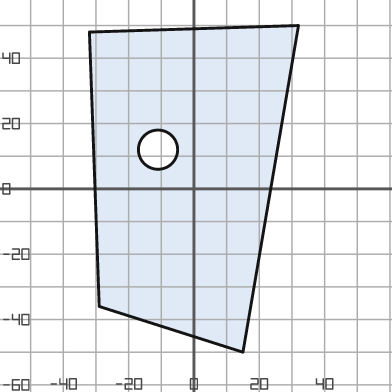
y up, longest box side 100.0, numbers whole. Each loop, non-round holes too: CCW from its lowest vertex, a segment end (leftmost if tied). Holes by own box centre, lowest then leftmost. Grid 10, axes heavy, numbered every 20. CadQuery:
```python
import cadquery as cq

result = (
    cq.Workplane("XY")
    .moveTo(15.0, -50.0)
    .lineTo(32.0, 50.0)
    .lineTo(-32.0, 48.0)
    .lineTo(-29.0, -36.0)
    .close()
    .moveTo(-11.0, 12.0)
    .circle(6.0)
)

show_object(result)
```